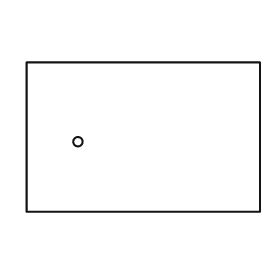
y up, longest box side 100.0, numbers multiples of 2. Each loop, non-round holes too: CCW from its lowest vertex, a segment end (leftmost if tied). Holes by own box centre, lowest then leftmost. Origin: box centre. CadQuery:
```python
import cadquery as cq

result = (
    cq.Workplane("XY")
    .moveTo(-50.0, -32.0)
    .lineTo(50.0, -32.0)
    .lineTo(50.0, 32.0)
    .lineTo(-50.0, 32.0)
    .close()
    .moveTo(-28.0, -2.0)
    .circle(2.0)
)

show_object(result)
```